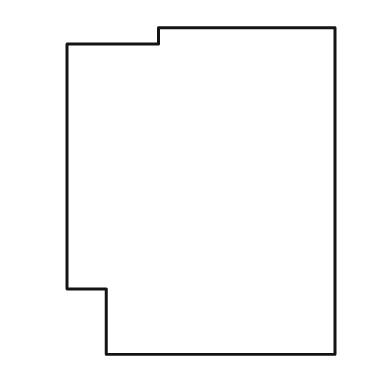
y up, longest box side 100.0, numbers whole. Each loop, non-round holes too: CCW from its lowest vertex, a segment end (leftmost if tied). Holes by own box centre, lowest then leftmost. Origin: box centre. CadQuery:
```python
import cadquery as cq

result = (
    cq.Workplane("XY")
    .moveTo(-29.0, -50.0)
    .lineTo(41.0, -50.0)
    .lineTo(41.0, 50.0)
    .lineTo(-13.0, 50.0)
    .lineTo(-13.0, 45.0)
    .lineTo(-41.0, 45.0)
    .lineTo(-41.0, -30.0)
    .lineTo(-29.0, -30.0)
    .close()
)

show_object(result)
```